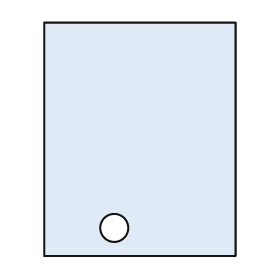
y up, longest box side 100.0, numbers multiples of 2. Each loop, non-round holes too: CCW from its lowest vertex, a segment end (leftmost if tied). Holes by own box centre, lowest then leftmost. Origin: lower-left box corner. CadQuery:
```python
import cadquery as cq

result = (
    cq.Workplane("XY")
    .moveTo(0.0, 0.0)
    .lineTo(82.0, 0.0)
    .lineTo(82.0, 100.0)
    .lineTo(0.0, 100.0)
    .close()
    .moveTo(30.0, 12.0)
    .circle(6.0)
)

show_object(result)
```